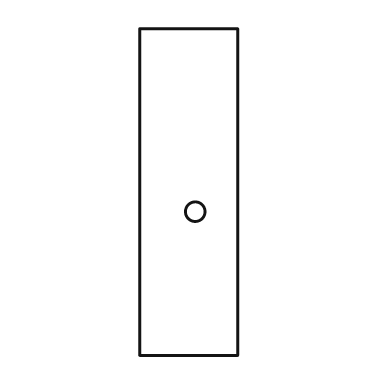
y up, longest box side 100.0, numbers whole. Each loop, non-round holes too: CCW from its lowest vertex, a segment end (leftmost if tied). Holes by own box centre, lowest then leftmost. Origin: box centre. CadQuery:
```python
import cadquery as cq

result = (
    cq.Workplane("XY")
    .moveTo(-15.0, -50.0)
    .lineTo(15.0, -50.0)
    .lineTo(15.0, 50.0)
    .lineTo(-15.0, 50.0)
    .close()
    .moveTo(2.0, -6.0)
    .circle(3.0)
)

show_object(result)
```